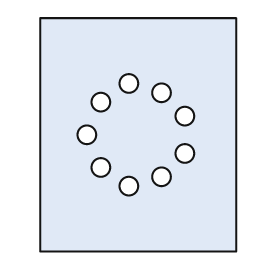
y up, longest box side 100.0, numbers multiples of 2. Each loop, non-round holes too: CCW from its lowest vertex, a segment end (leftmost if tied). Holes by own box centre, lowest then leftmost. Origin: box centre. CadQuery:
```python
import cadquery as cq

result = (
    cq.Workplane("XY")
    .moveTo(-42.0, -50.0)
    .lineTo(42.0, -50.0)
    .lineTo(42.0, 50.0)
    .lineTo(-42.0, 50.0)
    .close()
    .moveTo(-4.0, -22.0)
    .circle(4.0)
    .moveTo(10.0, -18.0)
    .circle(4.0)
    .moveTo(-16.0, -14.0)
    .circle(4.0)
    .moveTo(20.0, -8.0)
    .circle(4.0)
    .moveTo(-22.0, 0.0)
    .circle(4.0)
    .moveTo(20.0, 8.0)
    .circle(4.0)
    .moveTo(-16.0, 14.0)
    .circle(4.0)
    .moveTo(10.0, 18.0)
    .circle(4.0)
    .moveTo(-4.0, 22.0)
    .circle(4.0)
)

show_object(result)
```